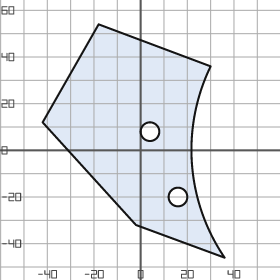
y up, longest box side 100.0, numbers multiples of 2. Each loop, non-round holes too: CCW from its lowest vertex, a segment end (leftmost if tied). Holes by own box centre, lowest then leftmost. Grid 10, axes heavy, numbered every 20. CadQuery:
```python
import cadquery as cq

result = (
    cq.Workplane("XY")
    .moveTo(36.0, -46.0)
    .threePointArc((22.0, -6.0), (30.0, 36.0))
    .lineTo(-18.0, 54.0)
    .lineTo(-42.0, 12.0)
    .lineTo(-2.0, -32.0)
    .close()
    .moveTo(16.0, -20.0)
    .circle(4.0)
    .moveTo(4.0, 8.0)
    .circle(4.0)
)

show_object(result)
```